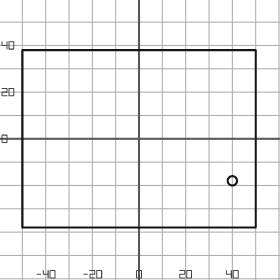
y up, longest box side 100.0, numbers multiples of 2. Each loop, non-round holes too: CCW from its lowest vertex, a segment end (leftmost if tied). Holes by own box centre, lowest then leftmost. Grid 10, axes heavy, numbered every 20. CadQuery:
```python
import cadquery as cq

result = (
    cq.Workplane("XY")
    .moveTo(-50.0, -38.0)
    .lineTo(50.0, -38.0)
    .lineTo(50.0, 38.0)
    .lineTo(-50.0, 38.0)
    .close()
    .moveTo(40.0, -18.0)
    .circle(2.0)
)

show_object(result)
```